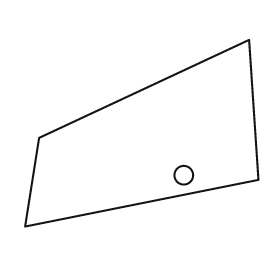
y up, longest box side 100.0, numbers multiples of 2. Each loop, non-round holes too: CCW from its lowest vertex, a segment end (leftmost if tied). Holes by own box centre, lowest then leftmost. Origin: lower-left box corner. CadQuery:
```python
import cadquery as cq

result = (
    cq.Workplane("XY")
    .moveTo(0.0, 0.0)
    .lineTo(100.0, 20.0)
    .lineTo(96.0, 80.0)
    .lineTo(6.0, 38.0)
    .close()
    .moveTo(68.0, 22.0)
    .circle(4.0)
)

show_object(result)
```